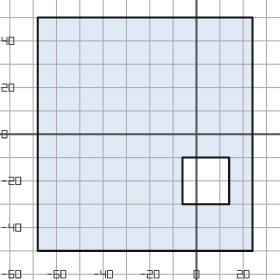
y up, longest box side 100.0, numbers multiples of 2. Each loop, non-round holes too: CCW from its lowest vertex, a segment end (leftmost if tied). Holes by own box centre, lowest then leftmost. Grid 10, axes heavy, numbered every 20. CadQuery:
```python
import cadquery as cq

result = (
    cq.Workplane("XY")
    .moveTo(-68.0, -50.0)
    .lineTo(24.0, -50.0)
    .lineTo(24.0, 50.0)
    .lineTo(-68.0, 50.0)
    .close()
    .moveTo(-6.0, -30.0)
    .lineTo(14.0, -30.0)
    .lineTo(14.0, -10.0)
    .lineTo(-6.0, -10.0)
    .close()
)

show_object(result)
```